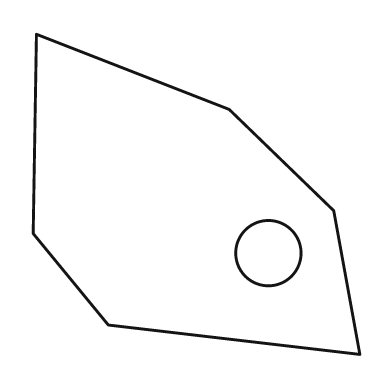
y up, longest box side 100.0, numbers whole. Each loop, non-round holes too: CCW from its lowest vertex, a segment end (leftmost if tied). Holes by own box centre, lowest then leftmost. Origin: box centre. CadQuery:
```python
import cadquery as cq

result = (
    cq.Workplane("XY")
    .moveTo(50.0, -49.0)
    .lineTo(42.0, -5.0)
    .lineTo(10.0, 26.0)
    .lineTo(-49.0, 49.0)
    .lineTo(-50.0, -12.0)
    .lineTo(-27.0, -40.0)
    .close()
    .moveTo(22.0, -18.0)
    .circle(10.0)
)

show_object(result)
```